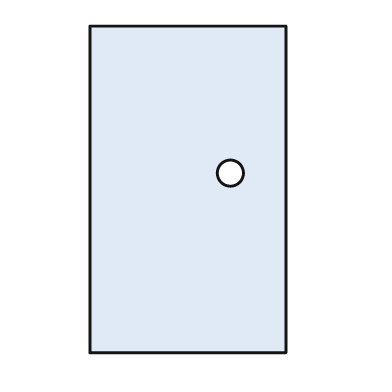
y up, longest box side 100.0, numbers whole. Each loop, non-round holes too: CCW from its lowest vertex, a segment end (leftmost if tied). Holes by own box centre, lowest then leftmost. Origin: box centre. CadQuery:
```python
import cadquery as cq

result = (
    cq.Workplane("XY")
    .moveTo(-30.0, -50.0)
    .lineTo(30.0, -50.0)
    .lineTo(30.0, 50.0)
    .lineTo(-30.0, 50.0)
    .close()
    .moveTo(13.0, 5.0)
    .circle(4.0)
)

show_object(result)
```